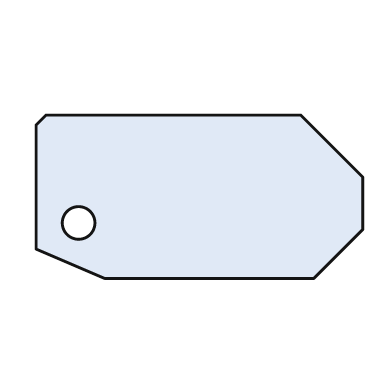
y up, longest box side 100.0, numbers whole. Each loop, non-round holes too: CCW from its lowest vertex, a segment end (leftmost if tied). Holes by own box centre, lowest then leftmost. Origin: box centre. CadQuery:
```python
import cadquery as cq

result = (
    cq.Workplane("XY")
    .moveTo(-29.0, -25.0)
    .lineTo(35.0, -25.0)
    .lineTo(50.0, -10.0)
    .lineTo(50.0, 6.0)
    .lineTo(31.0, 25.0)
    .lineTo(-47.0, 25.0)
    .lineTo(-50.0, 22.0)
    .lineTo(-50.0, -16.0)
    .close()
    .moveTo(-37.0, -8.0)
    .circle(5.0)
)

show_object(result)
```